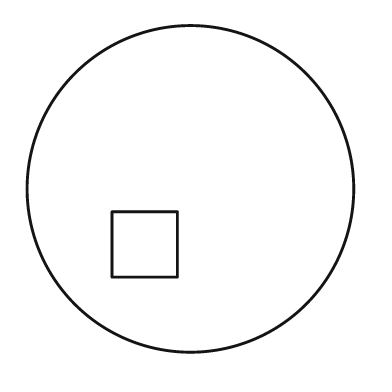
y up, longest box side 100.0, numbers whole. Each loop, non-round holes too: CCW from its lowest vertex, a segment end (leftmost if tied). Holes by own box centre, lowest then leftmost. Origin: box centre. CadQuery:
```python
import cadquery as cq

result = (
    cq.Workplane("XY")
    .moveTo(0.0, 0.0)
    .circle(50.0)
    .moveTo(-24.0, -27.0)
    .lineTo(-4.0, -27.0)
    .lineTo(-4.0, -7.0)
    .lineTo(-24.0, -7.0)
    .close()
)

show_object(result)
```